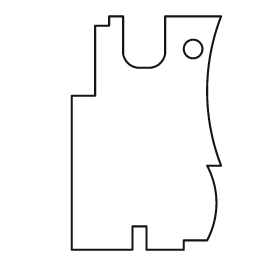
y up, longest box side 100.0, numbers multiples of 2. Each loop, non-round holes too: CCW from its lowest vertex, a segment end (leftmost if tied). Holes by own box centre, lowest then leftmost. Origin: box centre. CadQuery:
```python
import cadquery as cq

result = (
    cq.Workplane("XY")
    .moveTo(-32.0, -50.0)
    .lineTo(-6.0, -50.0)
    .lineTo(-6.0, -40.0)
    .lineTo(0.0, -40.0)
    .lineTo(0.0, -50.0)
    .lineTo(16.0, -50.0)
    .lineTo(16.0, -46.0)
    .lineTo(26.0, -46.0)
    .threePointArc((30.0, -30.0), (26.0, -14.0))
    .lineTo(32.0, -14.0)
    .threePointArc((26.0, 18.0), (32.0, 50.0))
    .lineTo(8.0, 50.0)
    .lineTo(8.0, 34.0)
    .threePointArc((6.0, 30.0), (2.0, 28.0))
    .lineTo(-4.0, 28.0)
    .threePointArc((-8.0, 30.0), (-10.0, 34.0))
    .lineTo(-10.0, 50.0)
    .lineTo(-16.0, 50.0)
    .lineTo(-16.0, 46.0)
    .lineTo(-22.0, 46.0)
    .lineTo(-22.0, 16.0)
    .lineTo(-32.0, 16.0)
    .close()
    .moveTo(20.0, 36.0)
    .circle(4.0)
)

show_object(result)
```